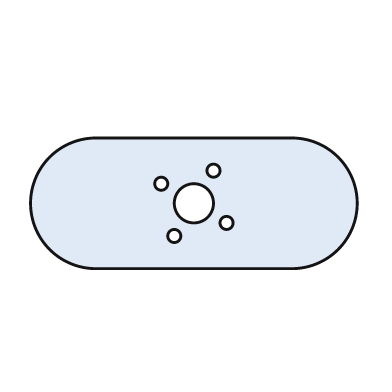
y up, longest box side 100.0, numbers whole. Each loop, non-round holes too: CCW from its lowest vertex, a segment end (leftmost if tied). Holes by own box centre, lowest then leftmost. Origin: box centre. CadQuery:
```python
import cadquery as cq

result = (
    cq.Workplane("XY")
    .moveTo(-30.0, -20.0)
    .lineTo(30.0, -20.0)
    .threePointArc((50.0, 0.0), (30.0, 20.0))
    .lineTo(-30.0, 20.0)
    .threePointArc((-50.0, 0.0), (-30.0, -20.0))
    .close()
    .moveTo(-6.0, -10.0)
    .circle(2.0)
    .moveTo(10.0, -6.0)
    .circle(2.0)
    .moveTo(0.0, 0.0)
    .circle(6.0)
    .moveTo(-10.0, 6.0)
    .circle(2.0)
    .moveTo(6.0, 10.0)
    .circle(2.0)
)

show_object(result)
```